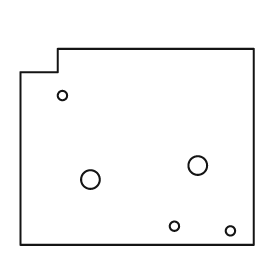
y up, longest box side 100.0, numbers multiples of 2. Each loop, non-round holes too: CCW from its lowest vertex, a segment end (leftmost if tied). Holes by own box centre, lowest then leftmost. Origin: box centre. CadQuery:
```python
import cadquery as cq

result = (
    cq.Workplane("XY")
    .moveTo(-50.0, -42.0)
    .lineTo(50.0, -42.0)
    .lineTo(50.0, 42.0)
    .lineTo(-34.0, 42.0)
    .lineTo(-34.0, 32.0)
    .lineTo(-50.0, 32.0)
    .close()
    .moveTo(40.0, -36.0)
    .circle(2.0)
    .moveTo(16.0, -34.0)
    .circle(2.0)
    .moveTo(-20.0, -14.0)
    .circle(4.0)
    .moveTo(26.0, -8.0)
    .circle(4.0)
    .moveTo(-32.0, 22.0)
    .circle(2.0)
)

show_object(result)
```